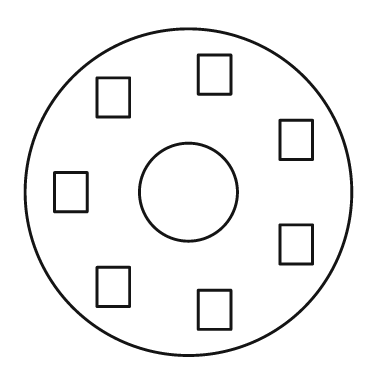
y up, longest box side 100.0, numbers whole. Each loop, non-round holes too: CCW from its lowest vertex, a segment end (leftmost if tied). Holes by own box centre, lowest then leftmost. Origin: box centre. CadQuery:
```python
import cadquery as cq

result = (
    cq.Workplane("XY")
    .moveTo(0.0, 0.0)
    .circle(50.0)
    .moveTo(3.0, -42.0)
    .lineTo(13.0, -42.0)
    .lineTo(13.0, -30.0)
    .lineTo(3.0, -30.0)
    .close()
    .moveTo(-28.0, -35.0)
    .lineTo(-18.0, -35.0)
    .lineTo(-18.0, -23.0)
    .lineTo(-28.0, -23.0)
    .close()
    .moveTo(28.0, -22.0)
    .lineTo(38.0, -22.0)
    .lineTo(38.0, -10.0)
    .lineTo(28.0, -10.0)
    .close()
    .moveTo(-41.0, -6.0)
    .lineTo(-31.0, -6.0)
    .lineTo(-31.0, 6.0)
    .lineTo(-41.0, 6.0)
    .close()
    .moveTo(0.0, 0.0)
    .circle(15.0)
    .moveTo(28.0, 10.0)
    .lineTo(38.0, 10.0)
    .lineTo(38.0, 22.0)
    .lineTo(28.0, 22.0)
    .close()
    .moveTo(-28.0, 23.0)
    .lineTo(-18.0, 23.0)
    .lineTo(-18.0, 35.0)
    .lineTo(-28.0, 35.0)
    .close()
    .moveTo(3.0, 30.0)
    .lineTo(13.0, 30.0)
    .lineTo(13.0, 42.0)
    .lineTo(3.0, 42.0)
    .close()
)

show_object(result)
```